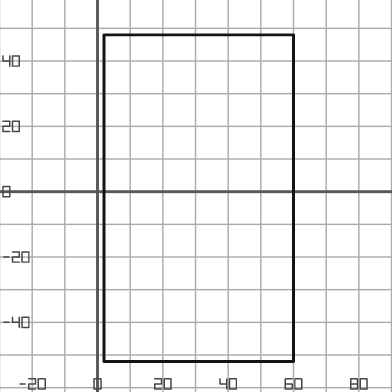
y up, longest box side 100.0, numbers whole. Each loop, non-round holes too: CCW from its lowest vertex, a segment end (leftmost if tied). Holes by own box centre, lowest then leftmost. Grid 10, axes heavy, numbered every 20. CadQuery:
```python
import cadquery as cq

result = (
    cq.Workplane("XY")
    .moveTo(2.0, -52.0)
    .lineTo(60.0, -52.0)
    .lineTo(60.0, 48.0)
    .lineTo(2.0, 48.0)
    .close()
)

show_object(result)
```